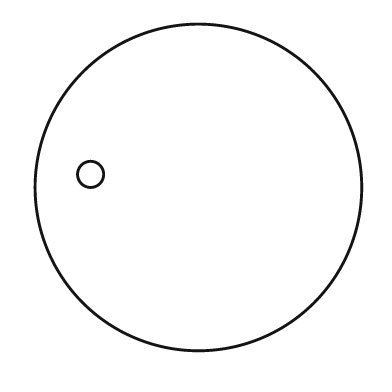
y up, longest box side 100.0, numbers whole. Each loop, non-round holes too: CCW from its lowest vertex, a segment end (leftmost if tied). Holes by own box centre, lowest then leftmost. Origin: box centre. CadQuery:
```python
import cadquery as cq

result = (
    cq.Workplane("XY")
    .moveTo(0.0, 0.0)
    .circle(50.0)
    .moveTo(-33.0, 4.0)
    .circle(4.0)
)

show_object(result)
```